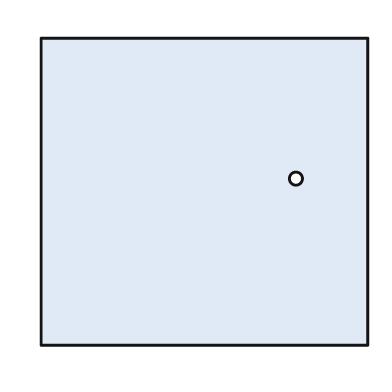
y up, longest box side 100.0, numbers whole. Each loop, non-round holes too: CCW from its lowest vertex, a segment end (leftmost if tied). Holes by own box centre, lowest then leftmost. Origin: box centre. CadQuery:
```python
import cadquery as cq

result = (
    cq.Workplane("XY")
    .moveTo(-50.0, -47.0)
    .lineTo(50.0, -47.0)
    .lineTo(50.0, 47.0)
    .lineTo(-50.0, 47.0)
    .close()
    .moveTo(28.0, 4.0)
    .circle(2.0)
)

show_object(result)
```